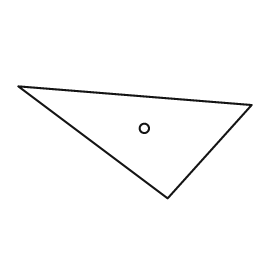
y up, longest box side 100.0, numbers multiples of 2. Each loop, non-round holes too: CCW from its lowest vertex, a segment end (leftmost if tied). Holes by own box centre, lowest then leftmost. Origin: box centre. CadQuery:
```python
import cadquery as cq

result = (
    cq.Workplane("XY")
    .moveTo(14.0, -24.0)
    .lineTo(50.0, 16.0)
    .lineTo(-50.0, 24.0)
    .close()
    .moveTo(4.0, 6.0)
    .circle(2.0)
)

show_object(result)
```